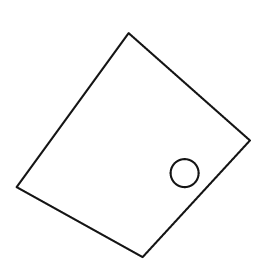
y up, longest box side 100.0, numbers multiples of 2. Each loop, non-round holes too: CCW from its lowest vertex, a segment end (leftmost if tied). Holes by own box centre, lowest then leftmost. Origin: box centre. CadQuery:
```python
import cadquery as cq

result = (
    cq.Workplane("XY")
    .moveTo(4.0, -48.0)
    .lineTo(50.0, 2.0)
    .lineTo(-2.0, 48.0)
    .lineTo(-50.0, -18.0)
    .close()
    .moveTo(22.0, -12.0)
    .circle(6.0)
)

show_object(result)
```